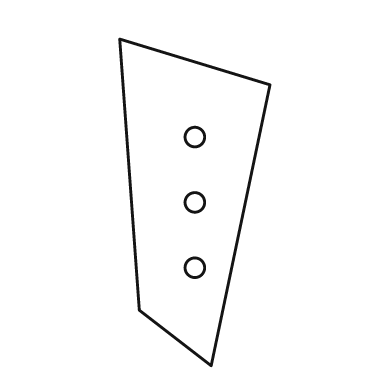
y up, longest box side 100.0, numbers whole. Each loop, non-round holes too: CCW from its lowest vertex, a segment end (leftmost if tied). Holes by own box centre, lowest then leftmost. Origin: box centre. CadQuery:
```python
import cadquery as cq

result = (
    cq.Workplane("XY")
    .moveTo(5.0, -50.0)
    .lineTo(23.0, 36.0)
    .lineTo(-23.0, 50.0)
    .lineTo(-17.0, -33.0)
    .close()
    .moveTo(0.0, -20.0)
    .circle(3.0)
    .moveTo(0.0, 0.0)
    .circle(3.0)
    .moveTo(0.0, 20.0)
    .circle(3.0)
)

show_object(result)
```